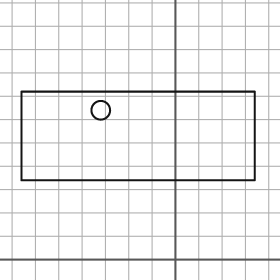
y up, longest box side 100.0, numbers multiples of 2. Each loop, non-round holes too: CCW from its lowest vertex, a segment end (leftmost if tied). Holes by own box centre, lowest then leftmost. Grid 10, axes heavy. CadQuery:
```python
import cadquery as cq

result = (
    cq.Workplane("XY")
    .moveTo(-66.0, 34.0)
    .lineTo(34.0, 34.0)
    .lineTo(34.0, 72.0)
    .lineTo(-66.0, 72.0)
    .close()
    .moveTo(-32.0, 64.0)
    .circle(4.0)
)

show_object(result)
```